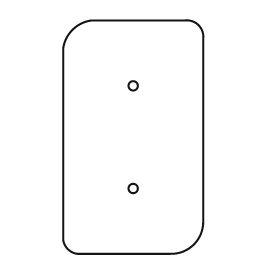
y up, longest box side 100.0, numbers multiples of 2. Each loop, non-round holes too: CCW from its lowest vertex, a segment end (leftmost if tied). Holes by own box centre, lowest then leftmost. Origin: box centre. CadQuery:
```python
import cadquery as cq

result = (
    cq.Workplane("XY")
    .moveTo(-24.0, -50.0)
    .lineTo(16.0, -50.0)
    .threePointArc((26.0, -46.0), (30.0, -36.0))
    .lineTo(30.0, 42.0)
    .threePointArc((28.0, 48.0), (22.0, 50.0))
    .lineTo(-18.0, 50.0)
    .threePointArc((-26.0, 46.0), (-30.0, 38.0))
    .lineTo(-30.0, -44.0)
    .threePointArc((-28.0, -48.0), (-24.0, -50.0))
    .close()
    .moveTo(0.0, -22.0)
    .circle(2.0)
    .moveTo(0.0, 22.0)
    .circle(2.0)
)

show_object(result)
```